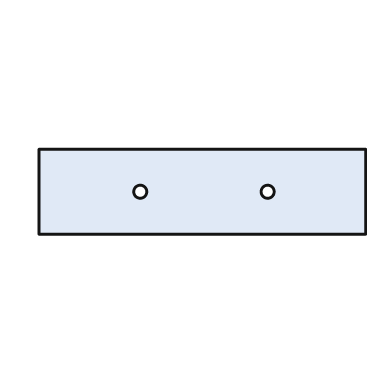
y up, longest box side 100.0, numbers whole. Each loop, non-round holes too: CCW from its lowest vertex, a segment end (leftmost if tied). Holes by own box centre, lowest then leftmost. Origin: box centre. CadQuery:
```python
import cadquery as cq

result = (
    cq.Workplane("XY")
    .moveTo(-50.0, -13.0)
    .lineTo(50.0, -13.0)
    .lineTo(50.0, 13.0)
    .lineTo(-50.0, 13.0)
    .close()
    .moveTo(-19.0, 0.0)
    .circle(2.0)
    .moveTo(20.0, 0.0)
    .circle(2.0)
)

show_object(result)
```